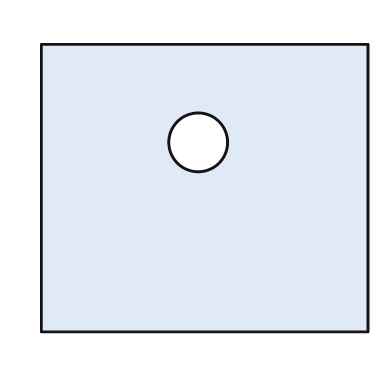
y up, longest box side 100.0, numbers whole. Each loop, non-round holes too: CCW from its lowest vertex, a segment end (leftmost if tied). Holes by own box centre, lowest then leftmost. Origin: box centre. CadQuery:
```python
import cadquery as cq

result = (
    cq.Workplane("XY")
    .moveTo(-50.0, -44.0)
    .lineTo(50.0, -44.0)
    .lineTo(50.0, 44.0)
    .lineTo(-50.0, 44.0)
    .close()
    .moveTo(-2.0, 14.0)
    .circle(9.0)
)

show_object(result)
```